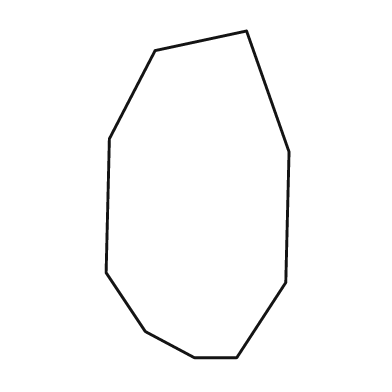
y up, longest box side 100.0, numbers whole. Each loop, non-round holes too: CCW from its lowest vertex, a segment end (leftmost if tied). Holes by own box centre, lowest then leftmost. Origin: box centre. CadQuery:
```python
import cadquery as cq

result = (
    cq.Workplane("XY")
    .moveTo(-1.0, -50.0)
    .lineTo(12.0, -50.0)
    .lineTo(27.0, -27.0)
    .lineTo(28.0, 13.0)
    .lineTo(15.0, 50.0)
    .lineTo(-13.0, 44.0)
    .lineTo(-27.0, 17.0)
    .lineTo(-28.0, -24.0)
    .lineTo(-16.0, -42.0)
    .close()
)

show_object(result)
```